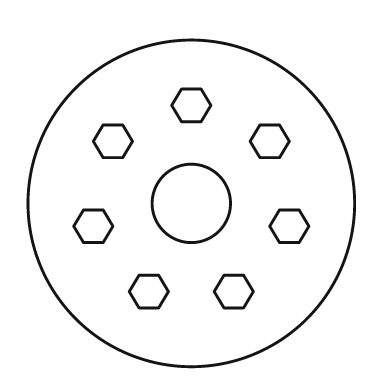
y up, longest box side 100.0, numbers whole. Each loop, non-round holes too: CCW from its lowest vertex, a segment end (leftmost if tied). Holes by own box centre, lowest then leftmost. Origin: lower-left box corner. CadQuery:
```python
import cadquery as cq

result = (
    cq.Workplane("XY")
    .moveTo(50.0, 50.0)
    .circle(50.0)
    .moveTo(34.0, 18.0)
    .lineTo(40.0, 18.0)
    .lineTo(43.0, 23.0)
    .lineTo(40.0, 28.0)
    .lineTo(34.0, 28.0)
    .lineTo(31.0, 23.0)
    .close()
    .moveTo(60.0, 18.0)
    .lineTo(66.0, 18.0)
    .lineTo(69.0, 23.0)
    .lineTo(66.0, 28.0)
    .lineTo(60.0, 28.0)
    .lineTo(57.0, 23.0)
    .close()
    .moveTo(17.0, 38.0)
    .lineTo(23.0, 38.0)
    .lineTo(26.0, 43.0)
    .lineTo(23.0, 48.0)
    .lineTo(17.0, 48.0)
    .lineTo(14.0, 43.0)
    .close()
    .moveTo(77.0, 38.0)
    .lineTo(83.0, 38.0)
    .lineTo(86.0, 43.0)
    .lineTo(83.0, 48.0)
    .lineTo(77.0, 48.0)
    .lineTo(74.0, 43.0)
    .close()
    .moveTo(50.0, 50.0)
    .circle(12.0)
    .moveTo(23.0, 64.0)
    .lineTo(29.0, 64.0)
    .lineTo(32.0, 69.0)
    .lineTo(29.0, 74.0)
    .lineTo(23.0, 74.0)
    .lineTo(20.0, 69.0)
    .close()
    .moveTo(71.0, 64.0)
    .lineTo(77.0, 64.0)
    .lineTo(80.0, 69.0)
    .lineTo(77.0, 74.0)
    .lineTo(71.0, 74.0)
    .lineTo(68.0, 69.0)
    .close()
    .moveTo(47.0, 75.0)
    .lineTo(53.0, 75.0)
    .lineTo(56.0, 80.0)
    .lineTo(53.0, 85.0)
    .lineTo(47.0, 85.0)
    .lineTo(44.0, 80.0)
    .close()
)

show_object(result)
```